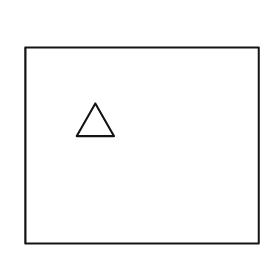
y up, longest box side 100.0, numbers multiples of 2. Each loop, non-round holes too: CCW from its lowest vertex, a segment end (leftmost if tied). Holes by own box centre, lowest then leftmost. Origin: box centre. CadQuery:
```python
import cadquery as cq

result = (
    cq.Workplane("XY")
    .moveTo(-50.0, -42.0)
    .lineTo(50.0, -42.0)
    .lineTo(50.0, 42.0)
    .lineTo(-50.0, 42.0)
    .close()
    .moveTo(-28.0, 4.0)
    .lineTo(-12.0, 4.0)
    .lineTo(-20.0, 18.0)
    .close()
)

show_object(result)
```